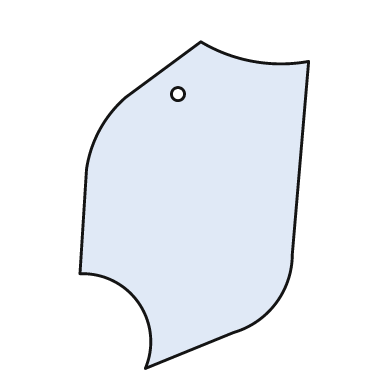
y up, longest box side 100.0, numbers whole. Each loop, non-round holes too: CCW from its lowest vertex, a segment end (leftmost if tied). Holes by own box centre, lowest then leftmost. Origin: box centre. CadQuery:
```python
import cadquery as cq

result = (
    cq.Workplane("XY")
    .moveTo(-15.0, -50.0)
    .lineTo(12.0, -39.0)
    .threePointArc((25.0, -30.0), (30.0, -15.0))
    .lineTo(35.0, 44.0)
    .threePointArc((18.0, 44.0), (2.0, 50.0))
    .lineTo(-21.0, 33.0)
    .threePointArc((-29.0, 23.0), (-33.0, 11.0))
    .lineTo(-35.0, -21.0)
    .threePointArc((-17.0, -30.0), (-15.0, -50.0))
    .close()
    .moveTo(-5.0, 34.0)
    .circle(2.0)
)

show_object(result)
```